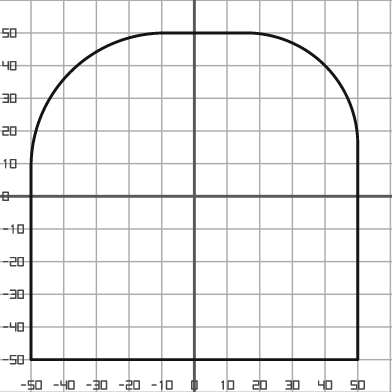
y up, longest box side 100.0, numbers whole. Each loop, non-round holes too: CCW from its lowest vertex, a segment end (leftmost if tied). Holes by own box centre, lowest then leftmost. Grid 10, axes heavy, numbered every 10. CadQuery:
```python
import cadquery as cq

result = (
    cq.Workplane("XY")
    .moveTo(-50.0, -50.0)
    .lineTo(50.0, -50.0)
    .lineTo(50.0, 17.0)
    .threePointArc((40.0, 40.0), (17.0, 50.0))
    .lineTo(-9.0, 50.0)
    .threePointArc((-38.0, 38.0), (-50.0, 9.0))
    .close()
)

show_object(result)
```